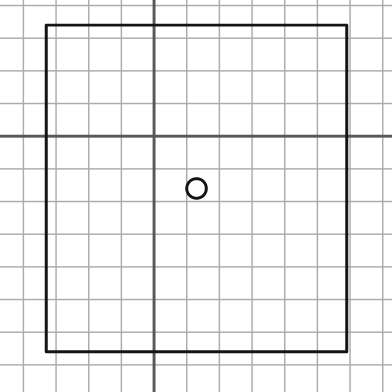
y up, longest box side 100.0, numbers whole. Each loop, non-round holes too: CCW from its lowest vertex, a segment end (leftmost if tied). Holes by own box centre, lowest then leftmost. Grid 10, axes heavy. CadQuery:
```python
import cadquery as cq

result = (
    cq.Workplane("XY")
    .moveTo(-33.0, -66.0)
    .lineTo(59.0, -66.0)
    .lineTo(59.0, 34.0)
    .lineTo(-33.0, 34.0)
    .close()
    .moveTo(13.0, -16.0)
    .circle(3.0)
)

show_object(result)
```